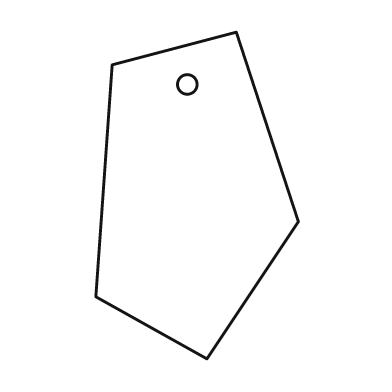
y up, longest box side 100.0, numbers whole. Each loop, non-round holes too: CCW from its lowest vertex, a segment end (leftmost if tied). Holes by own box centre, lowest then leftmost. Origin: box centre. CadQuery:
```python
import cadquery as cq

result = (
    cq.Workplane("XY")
    .moveTo(3.0, -50.0)
    .lineTo(31.0, -8.0)
    .lineTo(12.0, 50.0)
    .lineTo(-26.0, 40.0)
    .lineTo(-31.0, -31.0)
    .close()
    .moveTo(-3.0, 34.0)
    .circle(3.0)
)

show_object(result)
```